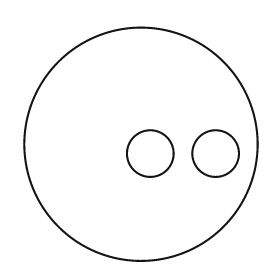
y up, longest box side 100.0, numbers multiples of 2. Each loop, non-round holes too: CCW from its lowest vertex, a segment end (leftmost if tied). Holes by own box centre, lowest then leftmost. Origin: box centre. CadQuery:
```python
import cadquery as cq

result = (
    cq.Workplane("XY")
    .moveTo(0.0, 0.0)
    .circle(50.0)
    .moveTo(4.0, -4.0)
    .circle(10.0)
    .moveTo(32.0, -4.0)
    .circle(10.0)
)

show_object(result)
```